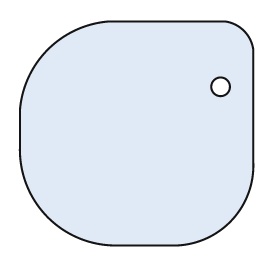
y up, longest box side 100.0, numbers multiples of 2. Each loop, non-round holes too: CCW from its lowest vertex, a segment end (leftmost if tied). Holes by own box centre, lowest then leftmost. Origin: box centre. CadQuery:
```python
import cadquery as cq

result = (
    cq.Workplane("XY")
    .moveTo(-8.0, -48.0)
    .lineTo(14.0, -48.0)
    .threePointArc((40.0, -38.0), (50.0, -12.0))
    .lineTo(50.0, 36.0)
    .threePointArc((46.0, 44.0), (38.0, 48.0))
    .lineTo(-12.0, 48.0)
    .threePointArc((-38.0, 36.0), (-50.0, 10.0))
    .lineTo(-50.0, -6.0)
    .threePointArc((-38.0, -36.0), (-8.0, -48.0))
    .close()
    .moveTo(36.0, 20.0)
    .circle(4.0)
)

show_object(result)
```